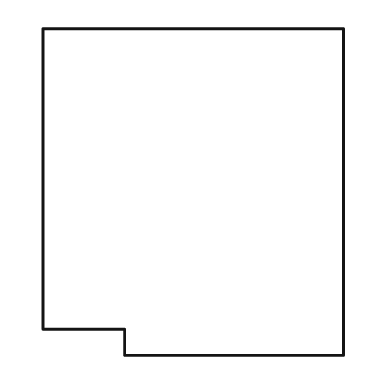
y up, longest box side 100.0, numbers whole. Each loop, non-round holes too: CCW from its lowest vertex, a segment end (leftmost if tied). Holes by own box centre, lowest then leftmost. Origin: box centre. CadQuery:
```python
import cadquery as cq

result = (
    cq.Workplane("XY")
    .moveTo(-21.0, -50.0)
    .lineTo(46.0, -50.0)
    .lineTo(46.0, 50.0)
    .lineTo(-46.0, 50.0)
    .lineTo(-46.0, -42.0)
    .lineTo(-21.0, -42.0)
    .close()
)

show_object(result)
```